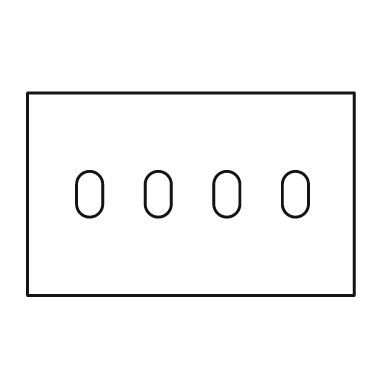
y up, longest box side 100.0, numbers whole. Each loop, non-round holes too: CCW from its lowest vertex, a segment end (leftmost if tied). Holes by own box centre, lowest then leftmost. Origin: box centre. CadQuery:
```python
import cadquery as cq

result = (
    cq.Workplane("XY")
    .moveTo(-50.0, -31.0)
    .lineTo(50.0, -31.0)
    .lineTo(50.0, 31.0)
    .lineTo(-50.0, 31.0)
    .close()
    .moveTo(-35.0, -3.0)
    .threePointArc((-31.0, -7.0), (-27.0, -3.0))
    .lineTo(-27.0, 3.0)
    .threePointArc((-31.0, 7.0), (-35.0, 3.0))
    .close()
    .moveTo(-14.0, -3.0)
    .threePointArc((-10.0, -7.0), (-6.0, -3.0))
    .lineTo(-6.0, 3.0)
    .threePointArc((-10.0, 7.0), (-14.0, 3.0))
    .close()
    .moveTo(7.0, -3.0)
    .threePointArc((11.0, -7.0), (15.0, -3.0))
    .lineTo(15.0, 3.0)
    .threePointArc((11.0, 7.0), (7.0, 3.0))
    .close()
    .moveTo(28.0, -3.0)
    .threePointArc((32.0, -7.0), (36.0, -3.0))
    .lineTo(36.0, 3.0)
    .threePointArc((32.0, 7.0), (28.0, 3.0))
    .close()
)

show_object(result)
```